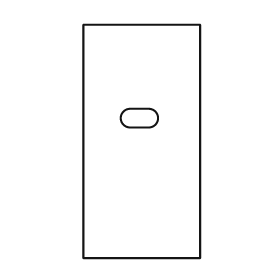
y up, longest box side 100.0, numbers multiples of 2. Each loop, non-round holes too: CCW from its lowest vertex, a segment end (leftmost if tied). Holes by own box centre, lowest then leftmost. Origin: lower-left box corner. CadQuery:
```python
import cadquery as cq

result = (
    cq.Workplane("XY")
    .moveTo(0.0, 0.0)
    .lineTo(50.0, 0.0)
    .lineTo(50.0, 100.0)
    .lineTo(0.0, 100.0)
    .close()
    .moveTo(20.0, 56.0)
    .lineTo(28.0, 56.0)
    .threePointArc((32.0, 60.0), (28.0, 64.0))
    .lineTo(20.0, 64.0)
    .threePointArc((16.0, 60.0), (20.0, 56.0))
    .close()
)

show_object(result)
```